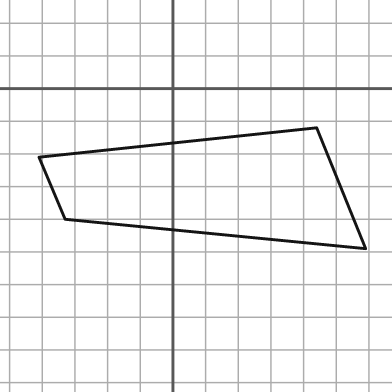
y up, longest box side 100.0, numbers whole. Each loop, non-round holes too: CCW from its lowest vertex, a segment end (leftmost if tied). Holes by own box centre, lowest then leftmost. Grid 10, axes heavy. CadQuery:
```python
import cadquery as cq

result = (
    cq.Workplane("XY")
    .moveTo(59.0, -49.0)
    .lineTo(44.0, -12.0)
    .lineTo(-41.0, -21.0)
    .lineTo(-33.0, -40.0)
    .close()
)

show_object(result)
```